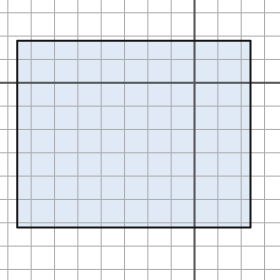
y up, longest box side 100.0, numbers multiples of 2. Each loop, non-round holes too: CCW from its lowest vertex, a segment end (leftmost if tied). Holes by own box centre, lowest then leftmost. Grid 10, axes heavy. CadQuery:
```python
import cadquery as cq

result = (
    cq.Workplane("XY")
    .moveTo(-76.0, -62.0)
    .lineTo(24.0, -62.0)
    .lineTo(24.0, 18.0)
    .lineTo(-76.0, 18.0)
    .close()
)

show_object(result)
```